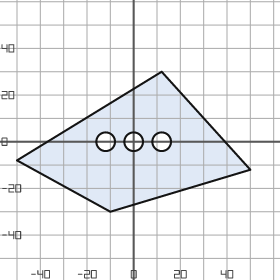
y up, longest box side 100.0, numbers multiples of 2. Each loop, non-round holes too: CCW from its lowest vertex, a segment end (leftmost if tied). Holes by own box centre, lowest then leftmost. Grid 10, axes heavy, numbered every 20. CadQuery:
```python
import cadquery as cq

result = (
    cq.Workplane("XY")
    .moveTo(-10.0, -30.0)
    .lineTo(50.0, -12.0)
    .lineTo(12.0, 30.0)
    .lineTo(-50.0, -8.0)
    .close()
    .moveTo(-12.0, 0.0)
    .circle(4.0)
    .moveTo(0.0, 0.0)
    .circle(4.0)
    .moveTo(12.0, 0.0)
    .circle(4.0)
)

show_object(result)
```